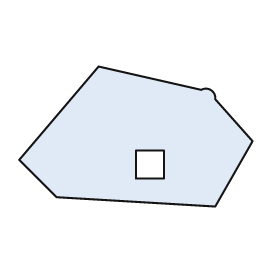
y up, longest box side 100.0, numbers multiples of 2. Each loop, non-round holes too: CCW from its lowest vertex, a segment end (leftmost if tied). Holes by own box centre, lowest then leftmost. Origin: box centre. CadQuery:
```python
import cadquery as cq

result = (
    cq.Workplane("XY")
    .moveTo(34.0, -30.0)
    .lineTo(50.0, -2.0)
    .lineTo(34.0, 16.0)
    .threePointArc((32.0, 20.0), (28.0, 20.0))
    .lineTo(-16.0, 30.0)
    .lineTo(-50.0, -10.0)
    .lineTo(-34.0, -26.0)
    .close()
    .moveTo(0.0, -18.0)
    .lineTo(12.0, -18.0)
    .lineTo(12.0, -6.0)
    .lineTo(0.0, -6.0)
    .close()
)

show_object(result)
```